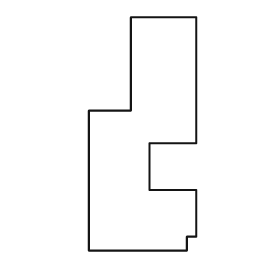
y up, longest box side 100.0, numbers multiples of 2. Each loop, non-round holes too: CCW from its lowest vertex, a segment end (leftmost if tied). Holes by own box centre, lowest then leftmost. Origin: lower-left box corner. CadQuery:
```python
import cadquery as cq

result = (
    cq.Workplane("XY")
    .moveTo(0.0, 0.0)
    .lineTo(42.0, 0.0)
    .lineTo(42.0, 6.0)
    .lineTo(46.0, 6.0)
    .lineTo(46.0, 26.0)
    .lineTo(26.0, 26.0)
    .lineTo(26.0, 46.0)
    .lineTo(46.0, 46.0)
    .lineTo(46.0, 100.0)
    .lineTo(18.0, 100.0)
    .lineTo(18.0, 60.0)
    .lineTo(0.0, 60.0)
    .close()
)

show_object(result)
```